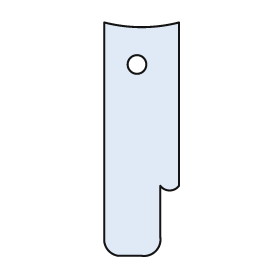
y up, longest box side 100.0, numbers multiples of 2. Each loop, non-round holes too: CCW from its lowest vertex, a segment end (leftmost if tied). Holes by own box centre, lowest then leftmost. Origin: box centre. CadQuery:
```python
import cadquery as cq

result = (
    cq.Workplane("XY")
    .moveTo(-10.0, -50.0)
    .lineTo(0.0, -50.0)
    .threePointArc((6.0, -48.0), (8.0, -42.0))
    .lineTo(8.0, -20.0)
    .threePointArc((12.0, -22.0), (16.0, -20.0))
    .lineTo(16.0, 50.0)
    .threePointArc((0.0, 48.0), (-16.0, 50.0))
    .lineTo(-16.0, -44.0)
    .threePointArc((-14.0, -48.0), (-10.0, -50.0))
    .close()
    .moveTo(-2.0, 32.0)
    .circle(4.0)
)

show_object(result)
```